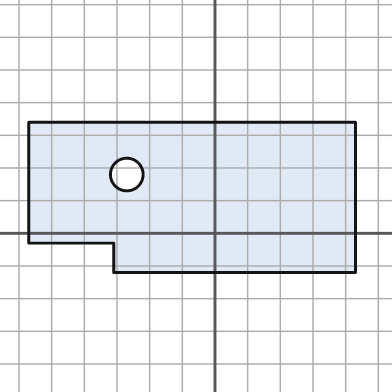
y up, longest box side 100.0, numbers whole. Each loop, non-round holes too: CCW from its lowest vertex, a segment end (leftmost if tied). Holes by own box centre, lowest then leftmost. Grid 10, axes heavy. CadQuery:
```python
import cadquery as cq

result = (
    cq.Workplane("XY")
    .moveTo(-31.0, -12.0)
    .lineTo(43.0, -12.0)
    .lineTo(43.0, 34.0)
    .lineTo(-57.0, 34.0)
    .lineTo(-57.0, -3.0)
    .lineTo(-31.0, -3.0)
    .close()
    .moveTo(-27.0, 18.0)
    .circle(5.0)
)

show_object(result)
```